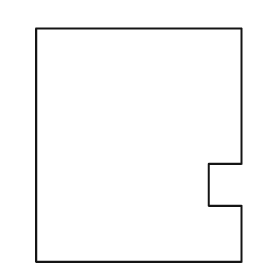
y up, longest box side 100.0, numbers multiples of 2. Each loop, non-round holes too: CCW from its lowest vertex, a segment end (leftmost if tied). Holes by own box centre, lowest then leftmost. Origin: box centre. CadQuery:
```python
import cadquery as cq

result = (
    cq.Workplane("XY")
    .moveTo(-44.0, -50.0)
    .lineTo(44.0, -50.0)
    .lineTo(44.0, -26.0)
    .lineTo(30.0, -26.0)
    .lineTo(30.0, -8.0)
    .lineTo(44.0, -8.0)
    .lineTo(44.0, 50.0)
    .lineTo(-44.0, 50.0)
    .close()
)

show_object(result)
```